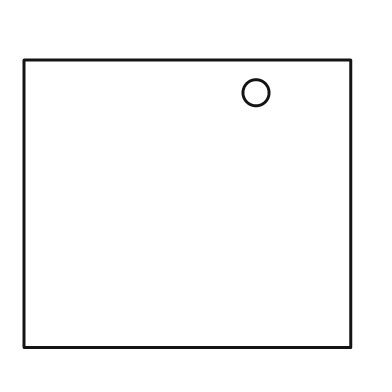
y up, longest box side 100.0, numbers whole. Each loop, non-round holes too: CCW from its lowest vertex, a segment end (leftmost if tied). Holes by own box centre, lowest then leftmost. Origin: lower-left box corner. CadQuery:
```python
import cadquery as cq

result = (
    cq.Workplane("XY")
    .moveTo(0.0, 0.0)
    .lineTo(100.0, 0.0)
    .lineTo(100.0, 88.0)
    .lineTo(0.0, 88.0)
    .close()
    .moveTo(71.0, 78.0)
    .circle(4.0)
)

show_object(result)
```